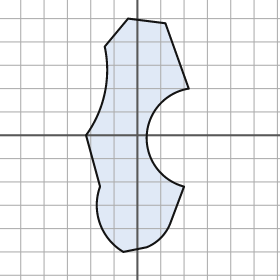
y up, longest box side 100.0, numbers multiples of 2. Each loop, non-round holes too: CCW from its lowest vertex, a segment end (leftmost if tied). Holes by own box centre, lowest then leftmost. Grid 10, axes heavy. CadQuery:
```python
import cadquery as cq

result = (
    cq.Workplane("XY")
    .moveTo(-6.0, -50.0)
    .lineTo(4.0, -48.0)
    .threePointArc((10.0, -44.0), (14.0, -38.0))
    .lineTo(20.0, -22.0)
    .threePointArc((4.0, 0.0), (22.0, 20.0))
    .lineTo(12.0, 48.0)
    .lineTo(-4.0, 50.0)
    .lineTo(-14.0, 38.0)
    .threePointArc((-14.0, 18.0), (-22.0, 0.0))
    .lineTo(-16.0, -22.0)
    .threePointArc((-16.0, -38.0), (-6.0, -50.0))
    .close()
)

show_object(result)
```